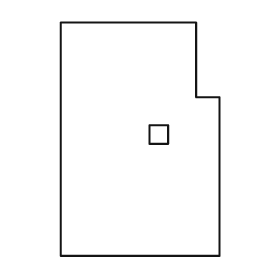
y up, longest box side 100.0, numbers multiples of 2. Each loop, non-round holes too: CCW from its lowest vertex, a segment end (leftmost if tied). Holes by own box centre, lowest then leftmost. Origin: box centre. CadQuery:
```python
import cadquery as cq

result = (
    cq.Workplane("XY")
    .moveTo(-34.0, -50.0)
    .lineTo(34.0, -50.0)
    .lineTo(34.0, 18.0)
    .lineTo(24.0, 18.0)
    .lineTo(24.0, 50.0)
    .lineTo(-34.0, 50.0)
    .close()
    .moveTo(4.0, -2.0)
    .lineTo(12.0, -2.0)
    .lineTo(12.0, 6.0)
    .lineTo(4.0, 6.0)
    .close()
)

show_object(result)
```